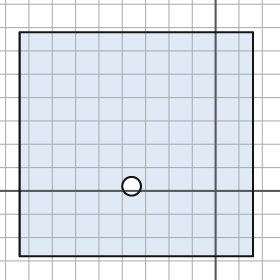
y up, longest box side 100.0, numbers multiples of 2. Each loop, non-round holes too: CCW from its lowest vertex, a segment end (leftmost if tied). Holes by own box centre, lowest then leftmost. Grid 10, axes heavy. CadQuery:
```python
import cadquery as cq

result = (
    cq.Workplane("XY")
    .moveTo(-84.0, -28.0)
    .lineTo(16.0, -28.0)
    .lineTo(16.0, 68.0)
    .lineTo(-84.0, 68.0)
    .close()
    .moveTo(-36.0, 2.0)
    .circle(4.0)
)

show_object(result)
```